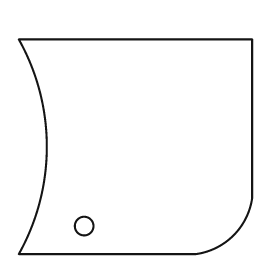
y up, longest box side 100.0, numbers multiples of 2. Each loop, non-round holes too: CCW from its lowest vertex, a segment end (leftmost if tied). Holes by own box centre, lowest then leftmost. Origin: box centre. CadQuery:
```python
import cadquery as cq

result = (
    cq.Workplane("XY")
    .moveTo(-50.0, -46.0)
    .lineTo(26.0, -46.0)
    .threePointArc((42.0, -38.0), (50.0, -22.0))
    .lineTo(50.0, 46.0)
    .lineTo(-50.0, 46.0)
    .threePointArc((-38.0, 0.0), (-50.0, -46.0))
    .close()
    .moveTo(-22.0, -34.0)
    .circle(4.0)
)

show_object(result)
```